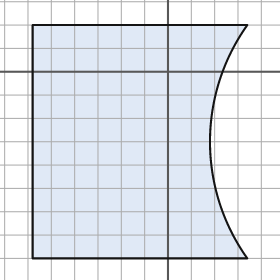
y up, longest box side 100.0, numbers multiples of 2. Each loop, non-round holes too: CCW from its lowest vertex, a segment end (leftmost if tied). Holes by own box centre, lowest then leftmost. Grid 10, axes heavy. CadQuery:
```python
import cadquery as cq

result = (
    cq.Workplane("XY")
    .moveTo(-58.0, -80.0)
    .lineTo(34.0, -80.0)
    .threePointArc((18.0, -30.0), (34.0, 20.0))
    .lineTo(-58.0, 20.0)
    .close()
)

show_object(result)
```